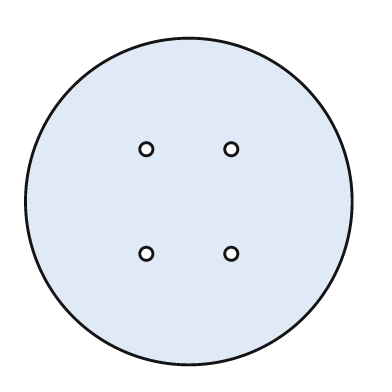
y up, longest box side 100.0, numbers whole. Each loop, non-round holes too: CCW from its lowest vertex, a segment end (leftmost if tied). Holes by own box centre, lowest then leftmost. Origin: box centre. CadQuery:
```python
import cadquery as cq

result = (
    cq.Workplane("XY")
    .moveTo(0.0, 0.0)
    .circle(50.0)
    .moveTo(-13.0, -16.0)
    .circle(2.0)
    .moveTo(13.0, -16.0)
    .circle(2.0)
    .moveTo(-13.0, 16.0)
    .circle(2.0)
    .moveTo(13.0, 16.0)
    .circle(2.0)
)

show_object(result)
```